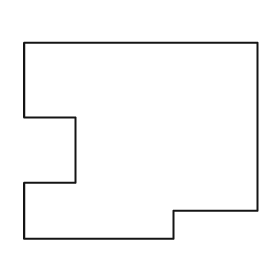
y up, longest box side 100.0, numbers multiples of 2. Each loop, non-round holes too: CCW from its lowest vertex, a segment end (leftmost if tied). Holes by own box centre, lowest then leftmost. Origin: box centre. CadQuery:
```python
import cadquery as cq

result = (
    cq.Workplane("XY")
    .moveTo(-50.0, -42.0)
    .lineTo(14.0, -42.0)
    .lineTo(14.0, -30.0)
    .lineTo(50.0, -30.0)
    .lineTo(50.0, 42.0)
    .lineTo(-50.0, 42.0)
    .lineTo(-50.0, 10.0)
    .lineTo(-28.0, 10.0)
    .lineTo(-28.0, -18.0)
    .lineTo(-50.0, -18.0)
    .close()
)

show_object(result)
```